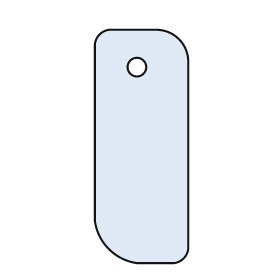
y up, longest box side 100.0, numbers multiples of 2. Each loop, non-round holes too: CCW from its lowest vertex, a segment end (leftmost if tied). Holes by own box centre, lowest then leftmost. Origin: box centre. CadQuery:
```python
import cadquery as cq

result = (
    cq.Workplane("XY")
    .moveTo(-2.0, -50.0)
    .lineTo(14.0, -50.0)
    .threePointArc((18.0, -48.0), (20.0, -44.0))
    .lineTo(20.0, 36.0)
    .threePointArc((16.0, 46.0), (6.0, 50.0))
    .lineTo(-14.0, 50.0)
    .threePointArc((-18.0, 48.0), (-20.0, 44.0))
    .lineTo(-20.0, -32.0)
    .threePointArc((-14.0, -44.0), (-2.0, -50.0))
    .close()
    .moveTo(-2.0, 34.0)
    .circle(4.0)
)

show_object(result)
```